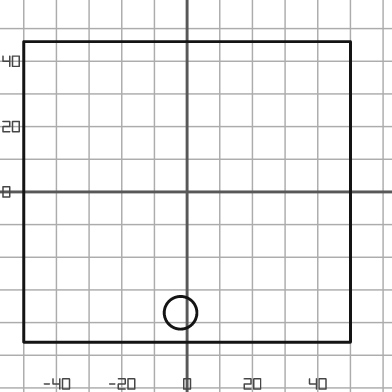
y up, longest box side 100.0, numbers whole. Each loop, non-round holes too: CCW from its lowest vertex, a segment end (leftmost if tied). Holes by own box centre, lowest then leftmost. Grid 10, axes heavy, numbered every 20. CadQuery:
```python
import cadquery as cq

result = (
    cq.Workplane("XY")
    .moveTo(-50.0, -46.0)
    .lineTo(50.0, -46.0)
    .lineTo(50.0, 46.0)
    .lineTo(-50.0, 46.0)
    .close()
    .moveTo(-2.0, -37.0)
    .circle(5.0)
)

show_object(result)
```